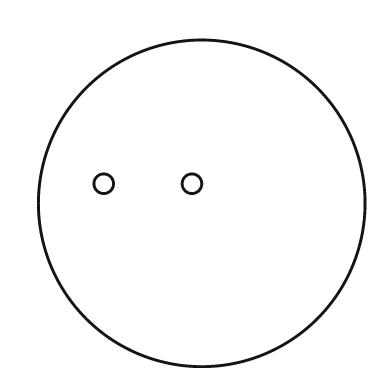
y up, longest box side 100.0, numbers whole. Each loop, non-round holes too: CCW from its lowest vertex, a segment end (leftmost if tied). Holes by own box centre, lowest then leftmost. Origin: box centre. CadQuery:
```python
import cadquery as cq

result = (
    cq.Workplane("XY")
    .moveTo(0.0, 0.0)
    .circle(50.0)
    .moveTo(-30.0, 6.0)
    .circle(3.0)
    .moveTo(-3.0, 6.0)
    .circle(3.0)
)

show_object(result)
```